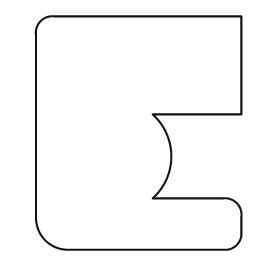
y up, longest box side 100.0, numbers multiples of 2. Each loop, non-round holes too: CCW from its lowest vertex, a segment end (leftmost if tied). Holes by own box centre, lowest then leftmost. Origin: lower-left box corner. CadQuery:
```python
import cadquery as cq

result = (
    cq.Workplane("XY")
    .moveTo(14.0, 0.0)
    .lineTo(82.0, 0.0)
    .threePointArc((86.0, 2.0), (88.0, 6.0))
    .lineTo(88.0, 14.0)
    .threePointArc((86.0, 20.0), (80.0, 22.0))
    .lineTo(50.0, 22.0)
    .threePointArc((58.0, 40.0), (50.0, 58.0))
    .lineTo(88.0, 58.0)
    .lineTo(88.0, 100.0)
    .lineTo(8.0, 100.0)
    .threePointArc((2.0, 98.0), (0.0, 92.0))
    .lineTo(0.0, 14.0)
    .threePointArc((4.0, 4.0), (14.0, 0.0))
    .close()
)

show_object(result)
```